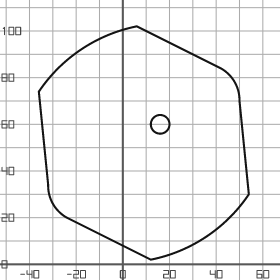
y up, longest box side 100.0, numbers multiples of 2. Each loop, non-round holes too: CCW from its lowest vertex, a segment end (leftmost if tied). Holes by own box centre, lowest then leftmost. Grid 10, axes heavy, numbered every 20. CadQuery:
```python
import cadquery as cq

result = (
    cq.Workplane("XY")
    .moveTo(12.0, 2.0)
    .threePointArc((36.0, 12.0), (54.0, 30.0))
    .lineTo(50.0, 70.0)
    .threePointArc((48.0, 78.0), (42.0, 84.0))
    .lineTo(6.0, 102.0)
    .threePointArc((-18.0, 92.0), (-36.0, 74.0))
    .lineTo(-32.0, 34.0)
    .threePointArc((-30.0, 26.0), (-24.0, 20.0))
    .close()
    .moveTo(16.0, 60.0)
    .circle(4.0)
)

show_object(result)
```